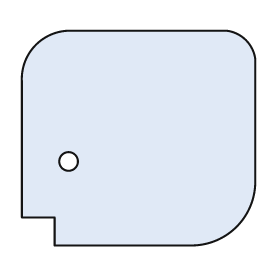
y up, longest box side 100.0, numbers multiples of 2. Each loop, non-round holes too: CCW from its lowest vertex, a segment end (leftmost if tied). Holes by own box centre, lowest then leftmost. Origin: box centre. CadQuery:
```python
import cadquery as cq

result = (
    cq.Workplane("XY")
    .moveTo(-36.0, -46.0)
    .lineTo(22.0, -46.0)
    .threePointArc((42.0, -38.0), (50.0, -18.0))
    .lineTo(50.0, 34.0)
    .threePointArc((46.0, 42.0), (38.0, 46.0))
    .lineTo(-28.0, 46.0)
    .threePointArc((-44.0, 40.0), (-50.0, 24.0))
    .lineTo(-50.0, -34.0)
    .lineTo(-36.0, -34.0)
    .close()
    .moveTo(-30.0, -10.0)
    .circle(4.0)
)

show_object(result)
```